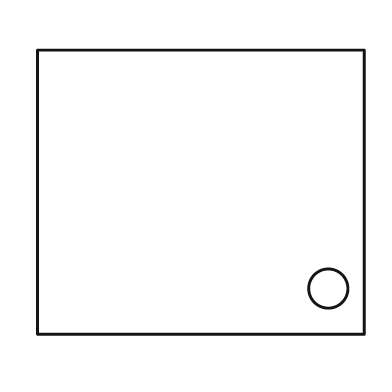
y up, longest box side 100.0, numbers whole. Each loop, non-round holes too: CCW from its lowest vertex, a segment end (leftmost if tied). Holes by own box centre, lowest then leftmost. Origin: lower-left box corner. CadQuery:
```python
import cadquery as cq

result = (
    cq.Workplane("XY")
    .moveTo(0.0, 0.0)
    .lineTo(100.0, 0.0)
    .lineTo(100.0, 87.0)
    .lineTo(0.0, 87.0)
    .close()
    .moveTo(89.0, 14.0)
    .circle(6.0)
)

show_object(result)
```